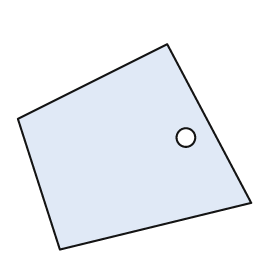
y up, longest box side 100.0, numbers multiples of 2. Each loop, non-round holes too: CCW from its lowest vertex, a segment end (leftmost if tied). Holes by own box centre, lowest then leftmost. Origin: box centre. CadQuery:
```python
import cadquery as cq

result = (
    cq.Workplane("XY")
    .moveTo(-32.0, -44.0)
    .lineTo(50.0, -24.0)
    .lineTo(14.0, 44.0)
    .lineTo(-50.0, 12.0)
    .close()
    .moveTo(22.0, 4.0)
    .circle(4.0)
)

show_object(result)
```